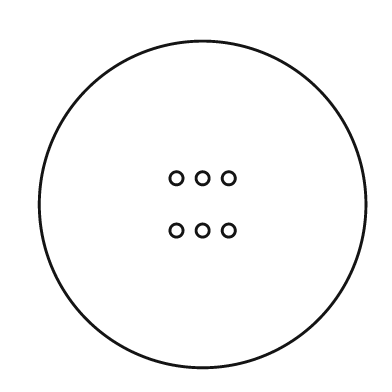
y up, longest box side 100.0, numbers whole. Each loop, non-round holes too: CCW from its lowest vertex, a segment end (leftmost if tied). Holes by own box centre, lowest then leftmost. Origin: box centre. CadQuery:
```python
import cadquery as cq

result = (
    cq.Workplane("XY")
    .moveTo(0.0, 0.0)
    .circle(50.0)
    .moveTo(-8.0, -8.0)
    .circle(2.0)
    .moveTo(0.0, -8.0)
    .circle(2.0)
    .moveTo(8.0, -8.0)
    .circle(2.0)
    .moveTo(-8.0, 8.0)
    .circle(2.0)
    .moveTo(0.0, 8.0)
    .circle(2.0)
    .moveTo(8.0, 8.0)
    .circle(2.0)
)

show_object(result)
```